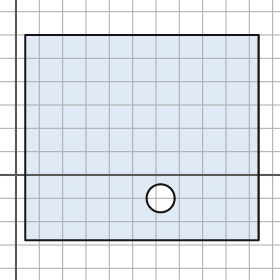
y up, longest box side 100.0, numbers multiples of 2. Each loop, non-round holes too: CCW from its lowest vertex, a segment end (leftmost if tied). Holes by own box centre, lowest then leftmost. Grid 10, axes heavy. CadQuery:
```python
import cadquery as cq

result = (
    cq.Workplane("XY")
    .moveTo(4.0, -28.0)
    .lineTo(104.0, -28.0)
    .lineTo(104.0, 60.0)
    .lineTo(4.0, 60.0)
    .close()
    .moveTo(62.0, -10.0)
    .circle(6.0)
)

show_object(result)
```